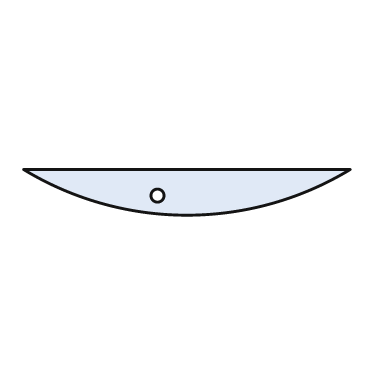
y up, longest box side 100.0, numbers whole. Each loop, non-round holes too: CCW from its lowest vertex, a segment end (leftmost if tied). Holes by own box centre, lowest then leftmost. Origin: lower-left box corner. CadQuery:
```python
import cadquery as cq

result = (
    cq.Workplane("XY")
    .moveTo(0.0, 14.0)
    .threePointArc((50.0, 0.0), (100.0, 14.0))
    .close()
    .moveTo(41.0, 6.0)
    .circle(2.0)
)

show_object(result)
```